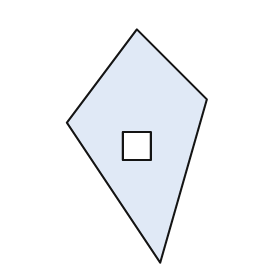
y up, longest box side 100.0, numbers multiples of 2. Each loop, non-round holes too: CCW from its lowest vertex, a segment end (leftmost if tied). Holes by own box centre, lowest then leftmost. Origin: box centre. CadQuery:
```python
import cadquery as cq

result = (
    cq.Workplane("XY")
    .moveTo(10.0, -50.0)
    .lineTo(30.0, 20.0)
    .lineTo(0.0, 50.0)
    .lineTo(-30.0, 10.0)
    .close()
    .moveTo(-6.0, -6.0)
    .lineTo(6.0, -6.0)
    .lineTo(6.0, 6.0)
    .lineTo(-6.0, 6.0)
    .close()
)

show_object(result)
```